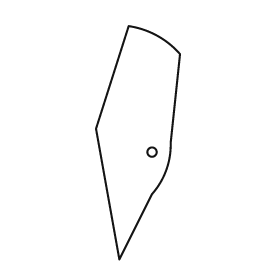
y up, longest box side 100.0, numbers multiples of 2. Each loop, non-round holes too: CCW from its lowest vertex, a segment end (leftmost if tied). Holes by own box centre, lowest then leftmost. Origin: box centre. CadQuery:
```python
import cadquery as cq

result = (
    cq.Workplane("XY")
    .moveTo(-8.0, -50.0)
    .lineTo(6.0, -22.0)
    .threePointArc((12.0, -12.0), (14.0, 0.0))
    .lineTo(18.0, 38.0)
    .threePointArc((8.0, 46.0), (-4.0, 50.0))
    .lineTo(-18.0, 6.0)
    .close()
    .moveTo(6.0, -4.0)
    .circle(2.0)
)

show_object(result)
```